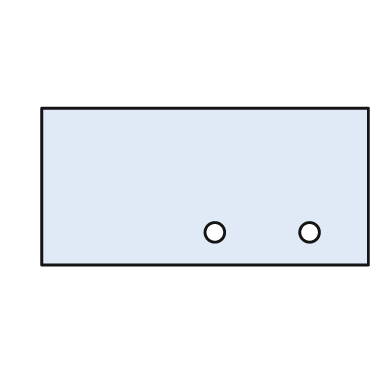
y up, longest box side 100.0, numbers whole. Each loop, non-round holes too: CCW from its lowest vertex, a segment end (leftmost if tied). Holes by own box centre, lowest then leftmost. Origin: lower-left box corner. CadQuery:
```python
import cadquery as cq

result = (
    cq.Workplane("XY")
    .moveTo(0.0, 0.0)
    .lineTo(100.0, 0.0)
    .lineTo(100.0, 48.0)
    .lineTo(0.0, 48.0)
    .close()
    .moveTo(53.0, 10.0)
    .circle(3.0)
    .moveTo(82.0, 10.0)
    .circle(3.0)
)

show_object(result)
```